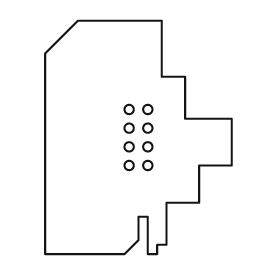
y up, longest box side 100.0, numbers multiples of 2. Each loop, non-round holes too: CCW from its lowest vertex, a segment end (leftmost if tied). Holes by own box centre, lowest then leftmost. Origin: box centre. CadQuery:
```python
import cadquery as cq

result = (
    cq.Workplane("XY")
    .moveTo(-40.0, -50.0)
    .lineTo(-6.0, -50.0)
    .lineTo(0.0, -44.0)
    .lineTo(0.0, -34.0)
    .lineTo(4.0, -34.0)
    .lineTo(4.0, -50.0)
    .lineTo(8.0, -50.0)
    .lineTo(8.0, -46.0)
    .lineTo(12.0, -46.0)
    .lineTo(12.0, -28.0)
    .lineTo(26.0, -28.0)
    .lineTo(26.0, -12.0)
    .lineTo(40.0, -12.0)
    .lineTo(40.0, 8.0)
    .lineTo(20.0, 8.0)
    .lineTo(20.0, 26.0)
    .lineTo(10.0, 26.0)
    .lineTo(10.0, 50.0)
    .lineTo(-26.0, 50.0)
    .lineTo(-40.0, 36.0)
    .close()
    .moveTo(-4.0, -12.0)
    .circle(2.0)
    .moveTo(4.0, -12.0)
    .circle(2.0)
    .moveTo(-4.0, -4.0)
    .circle(2.0)
    .moveTo(4.0, -4.0)
    .circle(2.0)
    .moveTo(-4.0, 4.0)
    .circle(2.0)
    .moveTo(4.0, 4.0)
    .circle(2.0)
    .moveTo(-4.0, 12.0)
    .circle(2.0)
    .moveTo(4.0, 12.0)
    .circle(2.0)
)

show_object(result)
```